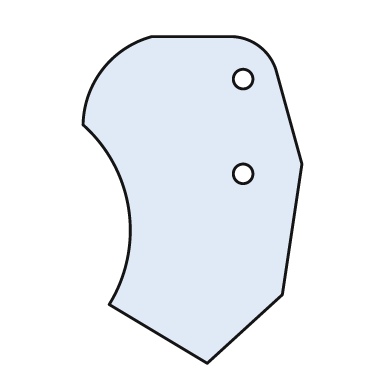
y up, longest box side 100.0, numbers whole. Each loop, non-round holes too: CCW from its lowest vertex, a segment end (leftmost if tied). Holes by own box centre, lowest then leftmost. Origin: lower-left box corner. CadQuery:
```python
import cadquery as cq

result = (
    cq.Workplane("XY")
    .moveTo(38.0, 0.0)
    .lineTo(61.0, 21.0)
    .lineTo(67.0, 61.0)
    .lineTo(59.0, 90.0)
    .threePointArc((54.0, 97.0), (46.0, 100.0))
    .lineTo(21.0, 100.0)
    .threePointArc((6.0, 90.0), (0.0, 73.0))
    .threePointArc((14.0, 47.0), (8.0, 18.0))
    .close()
    .moveTo(49.0, 58.0)
    .circle(3.0)
    .moveTo(49.0, 87.0)
    .circle(3.0)
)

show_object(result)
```